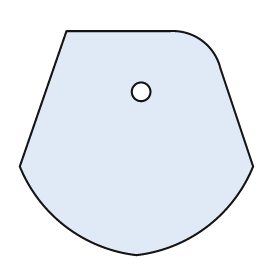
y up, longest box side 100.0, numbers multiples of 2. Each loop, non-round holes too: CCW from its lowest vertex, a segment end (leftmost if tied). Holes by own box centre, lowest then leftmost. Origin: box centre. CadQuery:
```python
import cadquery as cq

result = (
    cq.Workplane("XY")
    .moveTo(0.0, -48.0)
    .threePointArc((30.0, -36.0), (50.0, -10.0))
    .lineTo(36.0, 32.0)
    .threePointArc((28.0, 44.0), (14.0, 48.0))
    .lineTo(-30.0, 48.0)
    .lineTo(-50.0, -10.0)
    .threePointArc((-30.0, -36.0), (0.0, -48.0))
    .close()
    .moveTo(2.0, 22.0)
    .circle(4.0)
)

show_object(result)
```